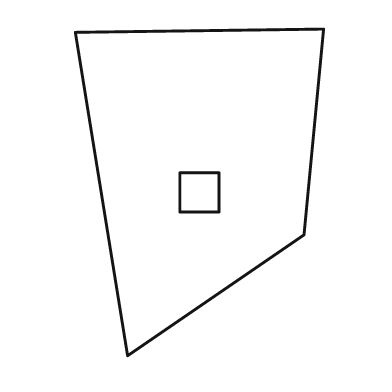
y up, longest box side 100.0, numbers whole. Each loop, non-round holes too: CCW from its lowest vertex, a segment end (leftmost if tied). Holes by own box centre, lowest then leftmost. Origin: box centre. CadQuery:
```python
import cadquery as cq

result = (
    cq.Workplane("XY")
    .moveTo(-22.0, -50.0)
    .lineTo(32.0, -13.0)
    .lineTo(38.0, 50.0)
    .lineTo(-38.0, 49.0)
    .close()
    .moveTo(-6.0, -6.0)
    .lineTo(6.0, -6.0)
    .lineTo(6.0, 6.0)
    .lineTo(-6.0, 6.0)
    .close()
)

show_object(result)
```